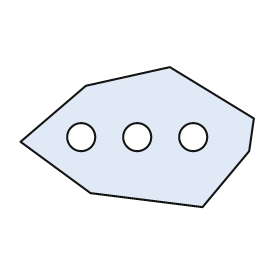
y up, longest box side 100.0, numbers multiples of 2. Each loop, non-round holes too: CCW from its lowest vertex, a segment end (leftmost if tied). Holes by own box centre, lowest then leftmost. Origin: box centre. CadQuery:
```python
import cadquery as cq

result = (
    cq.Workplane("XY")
    .moveTo(28.0, -30.0)
    .lineTo(48.0, -6.0)
    .lineTo(50.0, 8.0)
    .lineTo(14.0, 30.0)
    .lineTo(-22.0, 22.0)
    .lineTo(-50.0, -2.0)
    .lineTo(-20.0, -24.0)
    .close()
    .moveTo(-24.0, 0.0)
    .circle(6.0)
    .moveTo(0.0, 0.0)
    .circle(6.0)
    .moveTo(24.0, 0.0)
    .circle(6.0)
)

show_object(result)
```